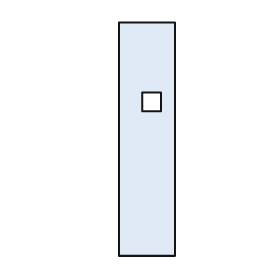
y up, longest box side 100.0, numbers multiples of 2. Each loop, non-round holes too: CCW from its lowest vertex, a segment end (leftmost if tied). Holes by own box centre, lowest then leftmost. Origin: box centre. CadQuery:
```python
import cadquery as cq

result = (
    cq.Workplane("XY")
    .moveTo(-12.0, -50.0)
    .lineTo(12.0, -50.0)
    .lineTo(12.0, 50.0)
    .lineTo(-12.0, 50.0)
    .close()
    .moveTo(-2.0, 12.0)
    .lineTo(6.0, 12.0)
    .lineTo(6.0, 20.0)
    .lineTo(-2.0, 20.0)
    .close()
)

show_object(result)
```